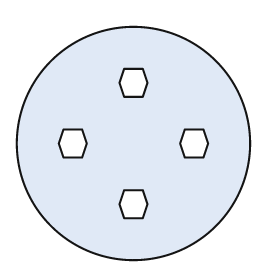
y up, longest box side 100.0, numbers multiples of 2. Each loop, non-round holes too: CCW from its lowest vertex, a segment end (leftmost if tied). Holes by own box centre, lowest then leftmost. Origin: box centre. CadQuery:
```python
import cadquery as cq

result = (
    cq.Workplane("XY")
    .moveTo(0.0, 0.0)
    .circle(50.0)
    .moveTo(-4.0, -32.0)
    .lineTo(4.0, -32.0)
    .lineTo(6.0, -26.0)
    .lineTo(4.0, -20.0)
    .lineTo(-4.0, -20.0)
    .lineTo(-6.0, -26.0)
    .close()
    .moveTo(-30.0, -6.0)
    .lineTo(-22.0, -6.0)
    .lineTo(-20.0, 0.0)
    .lineTo(-22.0, 6.0)
    .lineTo(-30.0, 6.0)
    .lineTo(-32.0, 0.0)
    .close()
    .moveTo(22.0, -6.0)
    .lineTo(30.0, -6.0)
    .lineTo(32.0, 0.0)
    .lineTo(30.0, 6.0)
    .lineTo(22.0, 6.0)
    .lineTo(20.0, 0.0)
    .close()
    .moveTo(-4.0, 20.0)
    .lineTo(4.0, 20.0)
    .lineTo(6.0, 26.0)
    .lineTo(4.0, 32.0)
    .lineTo(-4.0, 32.0)
    .lineTo(-6.0, 26.0)
    .close()
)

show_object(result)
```